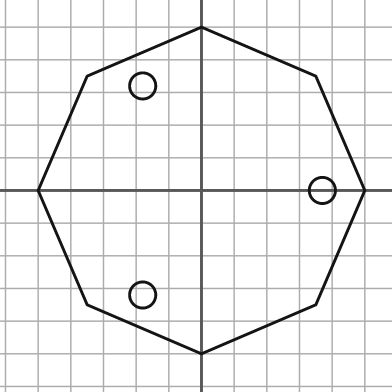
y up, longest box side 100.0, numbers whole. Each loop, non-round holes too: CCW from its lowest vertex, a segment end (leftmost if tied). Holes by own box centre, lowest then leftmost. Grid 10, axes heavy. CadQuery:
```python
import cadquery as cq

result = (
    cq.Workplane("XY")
    .moveTo(0.0, -50.0)
    .lineTo(35.0, -35.0)
    .lineTo(50.0, 0.0)
    .lineTo(35.0, 35.0)
    .lineTo(0.0, 50.0)
    .lineTo(-35.0, 35.0)
    .lineTo(-50.0, 0.0)
    .lineTo(-35.0, -35.0)
    .close()
    .moveTo(-18.0, -32.0)
    .circle(4.0)
    .moveTo(37.0, 0.0)
    .circle(4.0)
    .moveTo(-18.0, 32.0)
    .circle(4.0)
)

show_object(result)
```